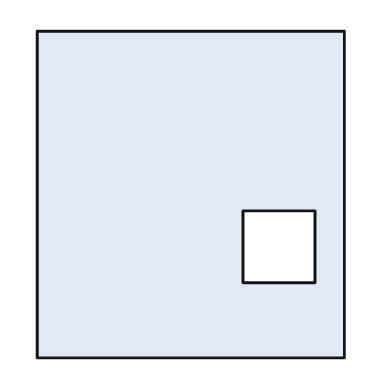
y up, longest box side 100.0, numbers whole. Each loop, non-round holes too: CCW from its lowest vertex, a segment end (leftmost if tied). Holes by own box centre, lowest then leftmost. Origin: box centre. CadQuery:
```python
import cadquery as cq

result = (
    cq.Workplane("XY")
    .moveTo(-47.0, -50.0)
    .lineTo(47.0, -50.0)
    .lineTo(47.0, 50.0)
    .lineTo(-47.0, 50.0)
    .close()
    .moveTo(16.0, -27.0)
    .lineTo(38.0, -27.0)
    .lineTo(38.0, -5.0)
    .lineTo(16.0, -5.0)
    .close()
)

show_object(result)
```